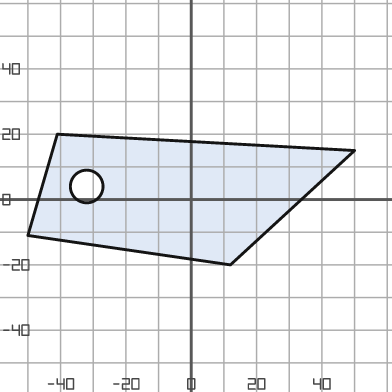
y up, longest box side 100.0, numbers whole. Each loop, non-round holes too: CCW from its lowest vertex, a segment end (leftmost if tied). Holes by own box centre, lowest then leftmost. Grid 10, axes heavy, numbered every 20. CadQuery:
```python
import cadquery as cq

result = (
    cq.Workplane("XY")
    .moveTo(12.0, -20.0)
    .lineTo(50.0, 15.0)
    .lineTo(-41.0, 20.0)
    .lineTo(-50.0, -11.0)
    .close()
    .moveTo(-32.0, 4.0)
    .circle(5.0)
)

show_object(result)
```